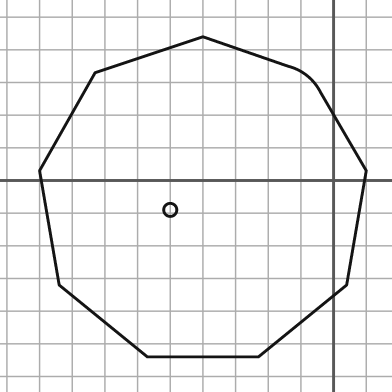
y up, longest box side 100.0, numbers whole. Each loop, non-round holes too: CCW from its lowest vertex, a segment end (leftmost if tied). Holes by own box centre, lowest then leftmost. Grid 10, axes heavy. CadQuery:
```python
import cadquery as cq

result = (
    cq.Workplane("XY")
    .moveTo(-57.0, -54.0)
    .lineTo(-23.0, -54.0)
    .lineTo(4.0, -32.0)
    .lineTo(10.0, 3.0)
    .lineTo(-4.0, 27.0)
    .threePointArc((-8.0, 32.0), (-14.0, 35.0))
    .lineTo(-40.0, 44.0)
    .lineTo(-73.0, 33.0)
    .lineTo(-90.0, 3.0)
    .lineTo(-84.0, -32.0)
    .close()
    .moveTo(-50.0, -9.0)
    .circle(2.0)
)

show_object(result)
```